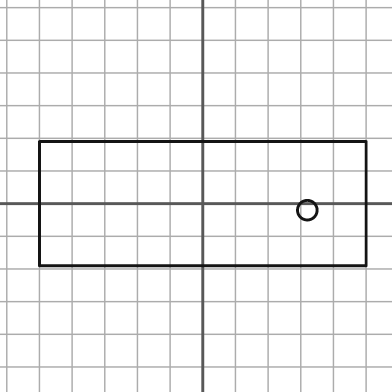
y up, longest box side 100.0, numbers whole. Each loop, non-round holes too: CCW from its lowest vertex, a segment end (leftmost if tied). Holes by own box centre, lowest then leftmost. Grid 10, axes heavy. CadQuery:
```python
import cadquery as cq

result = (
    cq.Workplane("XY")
    .moveTo(-50.0, -19.0)
    .lineTo(50.0, -19.0)
    .lineTo(50.0, 19.0)
    .lineTo(-50.0, 19.0)
    .close()
    .moveTo(32.0, -2.0)
    .circle(3.0)
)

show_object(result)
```